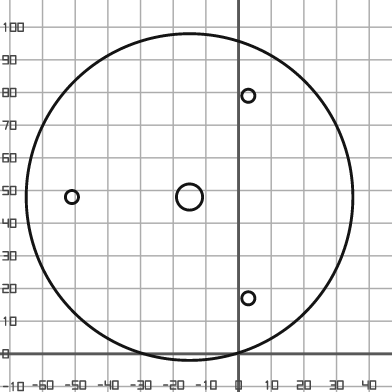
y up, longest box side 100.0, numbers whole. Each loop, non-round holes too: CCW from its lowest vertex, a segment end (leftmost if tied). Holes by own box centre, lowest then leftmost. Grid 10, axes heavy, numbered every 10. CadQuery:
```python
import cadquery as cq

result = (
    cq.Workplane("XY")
    .moveTo(-15.0, 48.0)
    .circle(50.0)
    .moveTo(3.0, 17.0)
    .circle(2.0)
    .moveTo(-51.0, 48.0)
    .circle(2.0)
    .moveTo(-15.0, 48.0)
    .circle(4.0)
    .moveTo(3.0, 79.0)
    .circle(2.0)
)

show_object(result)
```